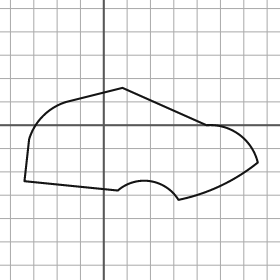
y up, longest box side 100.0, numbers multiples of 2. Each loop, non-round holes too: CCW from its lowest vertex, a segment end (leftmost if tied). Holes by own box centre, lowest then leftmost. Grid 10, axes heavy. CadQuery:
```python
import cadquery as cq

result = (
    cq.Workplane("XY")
    .moveTo(32.0, -32.0)
    .threePointArc((50.0, -26.0), (66.0, -16.0))
    .threePointArc((58.0, -4.0), (44.0, 0.0))
    .lineTo(8.0, 16.0)
    .lineTo(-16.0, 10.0)
    .threePointArc((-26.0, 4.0), (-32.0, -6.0))
    .lineTo(-34.0, -24.0)
    .lineTo(6.0, -28.0)
    .threePointArc((20.0, -24.0), (32.0, -32.0))
    .close()
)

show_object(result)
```